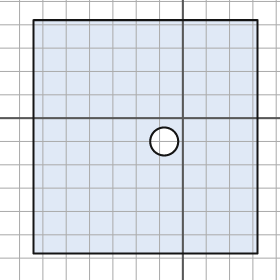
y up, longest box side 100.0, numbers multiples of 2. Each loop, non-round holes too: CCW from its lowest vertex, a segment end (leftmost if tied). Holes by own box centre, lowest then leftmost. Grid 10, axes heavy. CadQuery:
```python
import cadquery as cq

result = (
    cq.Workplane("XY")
    .moveTo(-64.0, -58.0)
    .lineTo(32.0, -58.0)
    .lineTo(32.0, 42.0)
    .lineTo(-64.0, 42.0)
    .close()
    .moveTo(-8.0, -10.0)
    .circle(6.0)
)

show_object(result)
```